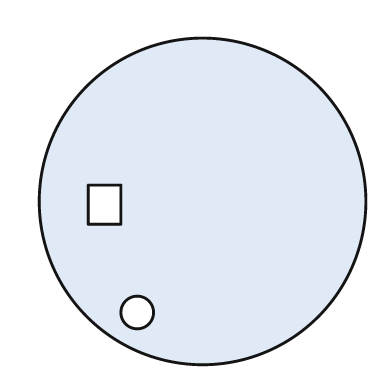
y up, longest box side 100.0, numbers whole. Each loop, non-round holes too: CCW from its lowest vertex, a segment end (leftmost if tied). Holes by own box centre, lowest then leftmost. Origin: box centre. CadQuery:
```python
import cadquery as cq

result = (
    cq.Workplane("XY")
    .moveTo(0.0, 0.0)
    .circle(50.0)
    .moveTo(-20.0, -34.0)
    .circle(5.0)
    .moveTo(-35.0, -7.0)
    .lineTo(-25.0, -7.0)
    .lineTo(-25.0, 5.0)
    .lineTo(-35.0, 5.0)
    .close()
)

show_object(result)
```